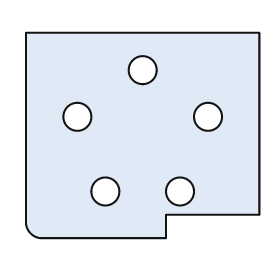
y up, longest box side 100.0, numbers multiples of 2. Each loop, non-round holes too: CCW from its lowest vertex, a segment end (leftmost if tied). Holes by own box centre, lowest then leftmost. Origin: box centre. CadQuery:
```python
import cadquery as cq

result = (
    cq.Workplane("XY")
    .moveTo(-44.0, -44.0)
    .lineTo(10.0, -44.0)
    .lineTo(10.0, -34.0)
    .lineTo(50.0, -34.0)
    .lineTo(50.0, 44.0)
    .lineTo(-50.0, 44.0)
    .lineTo(-50.0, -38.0)
    .threePointArc((-48.0, -42.0), (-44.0, -44.0))
    .close()
    .moveTo(-16.0, -24.0)
    .circle(6.0)
    .moveTo(16.0, -24.0)
    .circle(6.0)
    .moveTo(-28.0, 8.0)
    .circle(6.0)
    .moveTo(28.0, 8.0)
    .circle(6.0)
    .moveTo(0.0, 28.0)
    .circle(6.0)
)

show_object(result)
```